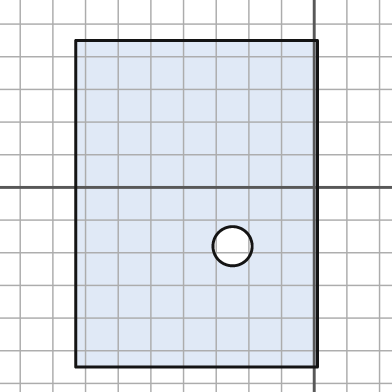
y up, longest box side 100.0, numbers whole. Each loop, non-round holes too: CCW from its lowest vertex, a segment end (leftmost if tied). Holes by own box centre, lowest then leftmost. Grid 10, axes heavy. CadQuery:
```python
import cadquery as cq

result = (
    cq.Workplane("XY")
    .moveTo(-73.0, -55.0)
    .lineTo(1.0, -55.0)
    .lineTo(1.0, 45.0)
    .lineTo(-73.0, 45.0)
    .close()
    .moveTo(-25.0, -18.0)
    .circle(6.0)
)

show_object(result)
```